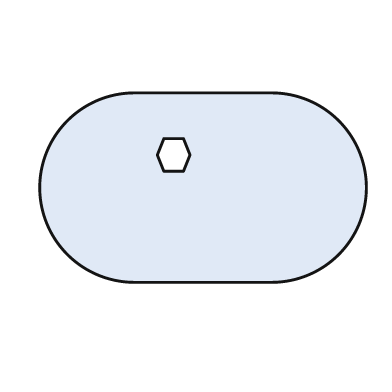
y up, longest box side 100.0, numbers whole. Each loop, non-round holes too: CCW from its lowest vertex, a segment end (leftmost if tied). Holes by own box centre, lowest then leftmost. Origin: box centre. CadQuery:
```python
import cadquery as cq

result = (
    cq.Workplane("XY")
    .moveTo(-21.0, -29.0)
    .lineTo(21.0, -29.0)
    .threePointArc((50.0, 0.0), (21.0, 29.0))
    .lineTo(-21.0, 29.0)
    .threePointArc((-50.0, 0.0), (-21.0, -29.0))
    .close()
    .moveTo(-12.0, 5.0)
    .lineTo(-6.0, 5.0)
    .lineTo(-4.0, 10.0)
    .lineTo(-6.0, 15.0)
    .lineTo(-12.0, 15.0)
    .lineTo(-14.0, 10.0)
    .close()
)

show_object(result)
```